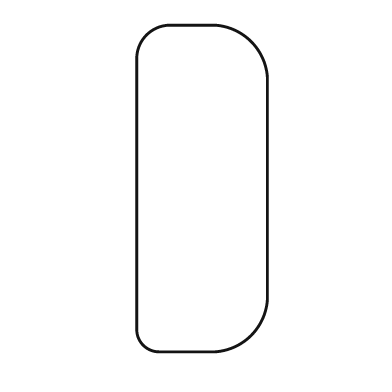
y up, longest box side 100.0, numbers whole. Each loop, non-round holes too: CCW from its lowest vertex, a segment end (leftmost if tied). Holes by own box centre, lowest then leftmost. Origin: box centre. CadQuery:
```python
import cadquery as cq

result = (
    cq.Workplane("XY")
    .moveTo(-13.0, -50.0)
    .lineTo(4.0, -50.0)
    .threePointArc((15.0, -45.0), (20.0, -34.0))
    .lineTo(20.0, 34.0)
    .threePointArc((15.0, 45.0), (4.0, 50.0))
    .lineTo(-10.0, 50.0)
    .threePointArc((-17.0, 47.0), (-20.0, 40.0))
    .lineTo(-20.0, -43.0)
    .threePointArc((-18.0, -48.0), (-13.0, -50.0))
    .close()
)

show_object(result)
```